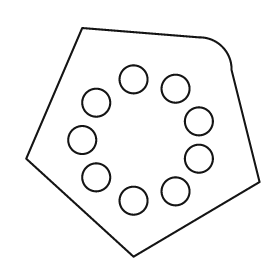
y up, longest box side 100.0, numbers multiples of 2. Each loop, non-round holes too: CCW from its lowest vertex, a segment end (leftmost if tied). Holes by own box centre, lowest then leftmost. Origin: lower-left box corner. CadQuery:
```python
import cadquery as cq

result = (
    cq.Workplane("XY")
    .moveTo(46.0, 0.0)
    .lineTo(100.0, 32.0)
    .lineTo(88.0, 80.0)
    .threePointArc((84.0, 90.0), (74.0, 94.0))
    .lineTo(24.0, 98.0)
    .lineTo(0.0, 42.0)
    .close()
    .moveTo(46.0, 24.0)
    .circle(6.0)
    .moveTo(64.0, 28.0)
    .circle(6.0)
    .moveTo(30.0, 34.0)
    .circle(6.0)
    .moveTo(74.0, 42.0)
    .circle(6.0)
    .moveTo(24.0, 50.0)
    .circle(6.0)
    .moveTo(74.0, 58.0)
    .circle(6.0)
    .moveTo(30.0, 66.0)
    .circle(6.0)
    .moveTo(64.0, 72.0)
    .circle(6.0)
    .moveTo(46.0, 76.0)
    .circle(6.0)
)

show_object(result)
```